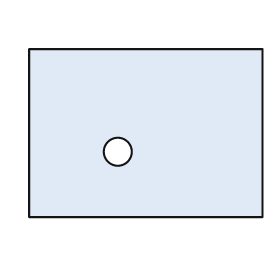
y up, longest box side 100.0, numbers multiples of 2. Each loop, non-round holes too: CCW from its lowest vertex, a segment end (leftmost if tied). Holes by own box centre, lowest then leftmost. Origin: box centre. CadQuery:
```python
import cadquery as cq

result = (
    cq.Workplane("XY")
    .moveTo(-50.0, -36.0)
    .lineTo(50.0, -36.0)
    .lineTo(50.0, 36.0)
    .lineTo(-50.0, 36.0)
    .close()
    .moveTo(-12.0, -8.0)
    .circle(6.0)
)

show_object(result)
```